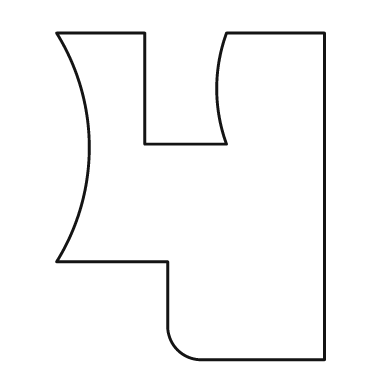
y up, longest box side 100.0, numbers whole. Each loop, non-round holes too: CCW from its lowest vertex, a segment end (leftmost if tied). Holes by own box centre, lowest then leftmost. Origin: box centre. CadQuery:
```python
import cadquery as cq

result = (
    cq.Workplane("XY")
    .moveTo(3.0, -50.0)
    .lineTo(41.0, -50.0)
    .lineTo(41.0, 50.0)
    .lineTo(11.0, 50.0)
    .threePointArc((8.0, 33.0), (11.0, 16.0))
    .lineTo(-14.0, 16.0)
    .lineTo(-14.0, 50.0)
    .lineTo(-41.0, 50.0)
    .threePointArc((-31.0, 15.0), (-41.0, -20.0))
    .lineTo(-7.0, -20.0)
    .lineTo(-7.0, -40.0)
    .threePointArc((-4.0, -47.0), (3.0, -50.0))
    .close()
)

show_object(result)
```